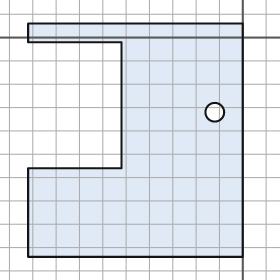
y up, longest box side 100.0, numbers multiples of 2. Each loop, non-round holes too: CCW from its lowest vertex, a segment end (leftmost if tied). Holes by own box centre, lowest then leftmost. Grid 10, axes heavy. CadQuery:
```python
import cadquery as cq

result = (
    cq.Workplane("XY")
    .moveTo(-92.0, -94.0)
    .lineTo(0.0, -94.0)
    .lineTo(0.0, 6.0)
    .lineTo(-92.0, 6.0)
    .lineTo(-92.0, -2.0)
    .lineTo(-52.0, -2.0)
    .lineTo(-52.0, -56.0)
    .lineTo(-92.0, -56.0)
    .close()
    .moveTo(-12.0, -32.0)
    .circle(4.0)
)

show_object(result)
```